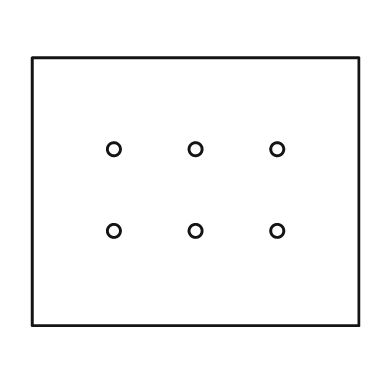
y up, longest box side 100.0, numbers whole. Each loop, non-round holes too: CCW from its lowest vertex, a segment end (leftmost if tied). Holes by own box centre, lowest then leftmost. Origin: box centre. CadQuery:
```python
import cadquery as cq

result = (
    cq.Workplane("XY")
    .moveTo(-50.0, -41.0)
    .lineTo(50.0, -41.0)
    .lineTo(50.0, 41.0)
    .lineTo(-50.0, 41.0)
    .close()
    .moveTo(-25.0, -12.0)
    .circle(2.0)
    .moveTo(0.0, -12.0)
    .circle(2.0)
    .moveTo(25.0, -12.0)
    .circle(2.0)
    .moveTo(-25.0, 13.0)
    .circle(2.0)
    .moveTo(0.0, 13.0)
    .circle(2.0)
    .moveTo(25.0, 13.0)
    .circle(2.0)
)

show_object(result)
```